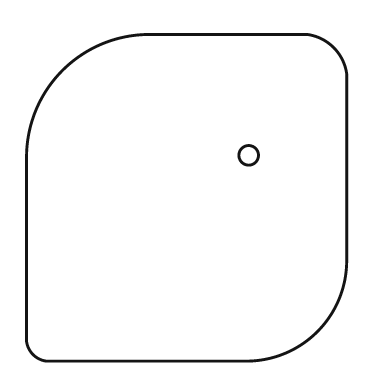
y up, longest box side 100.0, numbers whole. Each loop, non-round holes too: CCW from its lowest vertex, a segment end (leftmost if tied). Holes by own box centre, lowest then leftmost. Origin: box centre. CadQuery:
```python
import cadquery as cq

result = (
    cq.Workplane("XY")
    .moveTo(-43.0, -50.0)
    .lineTo(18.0, -50.0)
    .threePointArc((40.0, -41.0), (49.0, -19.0))
    .lineTo(49.0, 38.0)
    .threePointArc((45.0, 46.0), (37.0, 50.0))
    .lineTo(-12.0, 50.0)
    .threePointArc((-38.0, 39.0), (-49.0, 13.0))
    .lineTo(-49.0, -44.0)
    .threePointArc((-47.0, -48.0), (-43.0, -50.0))
    .close()
    .moveTo(19.0, 13.0)
    .circle(3.0)
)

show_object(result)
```